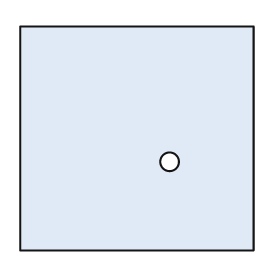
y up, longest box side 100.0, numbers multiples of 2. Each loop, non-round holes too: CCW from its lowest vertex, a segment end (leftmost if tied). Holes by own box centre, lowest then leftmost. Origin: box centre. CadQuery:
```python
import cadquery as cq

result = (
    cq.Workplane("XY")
    .moveTo(-50.0, -48.0)
    .lineTo(50.0, -48.0)
    .lineTo(50.0, 48.0)
    .lineTo(-50.0, 48.0)
    .close()
    .moveTo(14.0, -10.0)
    .circle(4.0)
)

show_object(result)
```